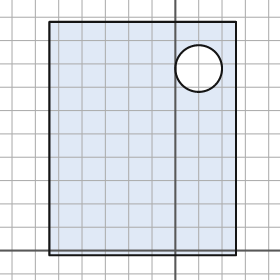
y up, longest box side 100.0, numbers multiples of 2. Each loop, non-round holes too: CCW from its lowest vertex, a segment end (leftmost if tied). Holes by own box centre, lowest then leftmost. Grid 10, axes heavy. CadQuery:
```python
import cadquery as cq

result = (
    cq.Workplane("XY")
    .moveTo(-54.0, -2.0)
    .lineTo(26.0, -2.0)
    .lineTo(26.0, 98.0)
    .lineTo(-54.0, 98.0)
    .close()
    .moveTo(10.0, 78.0)
    .circle(10.0)
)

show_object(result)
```